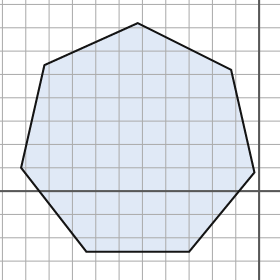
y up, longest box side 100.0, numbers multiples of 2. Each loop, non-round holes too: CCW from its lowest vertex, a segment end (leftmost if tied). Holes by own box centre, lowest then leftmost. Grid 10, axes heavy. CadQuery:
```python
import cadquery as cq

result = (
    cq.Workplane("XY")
    .moveTo(-74.0, -26.0)
    .lineTo(-30.0, -26.0)
    .lineTo(-2.0, 8.0)
    .lineTo(-12.0, 52.0)
    .lineTo(-52.0, 72.0)
    .lineTo(-92.0, 54.0)
    .lineTo(-102.0, 10.0)
    .close()
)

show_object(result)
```